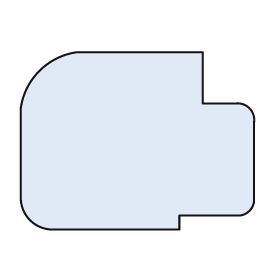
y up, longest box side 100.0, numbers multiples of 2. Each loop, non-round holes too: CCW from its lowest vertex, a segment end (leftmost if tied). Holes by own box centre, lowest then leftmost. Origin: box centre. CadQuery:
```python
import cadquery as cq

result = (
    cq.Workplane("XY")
    .moveTo(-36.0, -38.0)
    .lineTo(18.0, -38.0)
    .lineTo(18.0, -32.0)
    .lineTo(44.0, -32.0)
    .threePointArc((48.0, -30.0), (50.0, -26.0))
    .lineTo(50.0, 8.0)
    .threePointArc((48.0, 14.0), (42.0, 16.0))
    .lineTo(28.0, 16.0)
    .lineTo(28.0, 38.0)
    .lineTo(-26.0, 38.0)
    .threePointArc((-42.0, 30.0), (-50.0, 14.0))
    .lineTo(-50.0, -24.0)
    .threePointArc((-46.0, -34.0), (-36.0, -38.0))
    .close()
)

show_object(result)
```